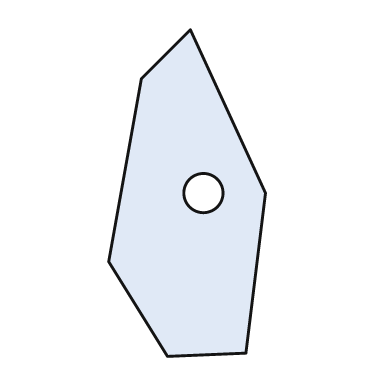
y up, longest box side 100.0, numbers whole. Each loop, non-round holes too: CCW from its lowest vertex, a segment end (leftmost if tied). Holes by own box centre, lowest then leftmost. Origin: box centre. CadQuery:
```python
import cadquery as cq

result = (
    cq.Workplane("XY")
    .moveTo(-6.0, -50.0)
    .lineTo(18.0, -49.0)
    .lineTo(24.0, 0.0)
    .lineTo(1.0, 50.0)
    .lineTo(-14.0, 35.0)
    .lineTo(-24.0, -21.0)
    .close()
    .moveTo(5.0, 0.0)
    .circle(6.0)
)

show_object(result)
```